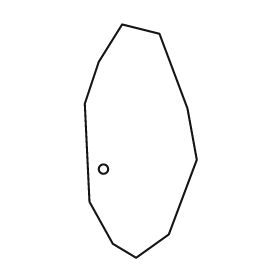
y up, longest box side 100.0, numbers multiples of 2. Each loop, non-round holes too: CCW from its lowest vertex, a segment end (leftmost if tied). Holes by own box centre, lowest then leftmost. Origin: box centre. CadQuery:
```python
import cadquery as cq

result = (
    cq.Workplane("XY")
    .moveTo(-2.0, -50.0)
    .lineTo(12.0, -40.0)
    .lineTo(24.0, -8.0)
    .lineTo(20.0, 14.0)
    .lineTo(8.0, 46.0)
    .lineTo(-8.0, 50.0)
    .lineTo(-18.0, 34.0)
    .lineTo(-24.0, 16.0)
    .lineTo(-22.0, -26.0)
    .lineTo(-12.0, -44.0)
    .close()
    .moveTo(-16.0, -12.0)
    .circle(2.0)
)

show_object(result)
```